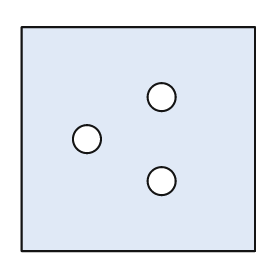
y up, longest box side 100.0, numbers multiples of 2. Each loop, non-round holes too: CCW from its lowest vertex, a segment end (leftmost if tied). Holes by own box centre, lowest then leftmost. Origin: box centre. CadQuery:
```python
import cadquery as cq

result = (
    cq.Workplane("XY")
    .moveTo(-50.0, -48.0)
    .lineTo(50.0, -48.0)
    .lineTo(50.0, 48.0)
    .lineTo(-50.0, 48.0)
    .close()
    .moveTo(10.0, -18.0)
    .circle(6.0)
    .moveTo(-22.0, 0.0)
    .circle(6.0)
    .moveTo(10.0, 18.0)
    .circle(6.0)
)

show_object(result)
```